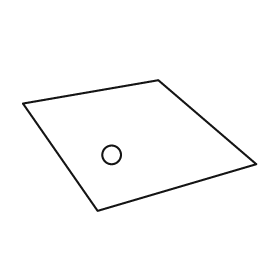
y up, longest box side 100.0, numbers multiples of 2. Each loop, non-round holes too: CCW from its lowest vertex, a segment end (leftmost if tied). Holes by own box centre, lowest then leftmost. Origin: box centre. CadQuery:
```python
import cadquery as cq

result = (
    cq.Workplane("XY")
    .moveTo(-18.0, -28.0)
    .lineTo(50.0, -8.0)
    .lineTo(8.0, 28.0)
    .lineTo(-50.0, 18.0)
    .close()
    .moveTo(-12.0, -4.0)
    .circle(4.0)
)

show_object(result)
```